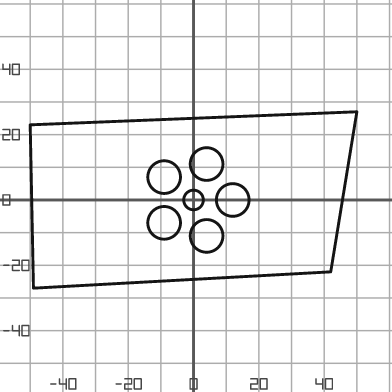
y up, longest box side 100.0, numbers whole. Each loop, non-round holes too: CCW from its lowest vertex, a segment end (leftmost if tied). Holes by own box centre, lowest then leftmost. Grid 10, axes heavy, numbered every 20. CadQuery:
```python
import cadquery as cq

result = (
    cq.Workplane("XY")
    .moveTo(-49.0, -27.0)
    .lineTo(42.0, -22.0)
    .lineTo(50.0, 27.0)
    .lineTo(-50.0, 23.0)
    .close()
    .moveTo(4.0, -11.0)
    .circle(5.0)
    .moveTo(-9.0, -7.0)
    .circle(5.0)
    .moveTo(0.0, 0.0)
    .circle(3.0)
    .moveTo(12.0, 0.0)
    .circle(5.0)
    .moveTo(-9.0, 7.0)
    .circle(5.0)
    .moveTo(4.0, 11.0)
    .circle(5.0)
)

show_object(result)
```